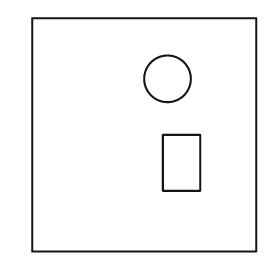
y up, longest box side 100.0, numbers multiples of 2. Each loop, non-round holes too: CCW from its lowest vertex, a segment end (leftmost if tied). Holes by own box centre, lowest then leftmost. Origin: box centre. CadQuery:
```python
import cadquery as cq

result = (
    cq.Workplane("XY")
    .moveTo(-48.0, -50.0)
    .lineTo(48.0, -50.0)
    .lineTo(48.0, 50.0)
    .lineTo(-48.0, 50.0)
    .close()
    .moveTo(8.0, -24.0)
    .lineTo(24.0, -24.0)
    .lineTo(24.0, 0.0)
    .lineTo(8.0, 0.0)
    .close()
    .moveTo(10.0, 24.0)
    .circle(10.0)
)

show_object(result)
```